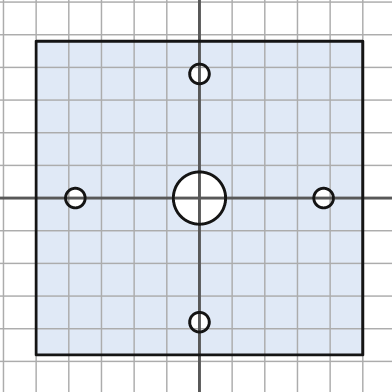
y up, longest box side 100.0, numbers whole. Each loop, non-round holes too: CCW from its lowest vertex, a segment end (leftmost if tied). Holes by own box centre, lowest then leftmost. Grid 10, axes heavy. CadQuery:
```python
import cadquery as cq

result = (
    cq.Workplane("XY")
    .moveTo(-50.0, -48.0)
    .lineTo(50.0, -48.0)
    .lineTo(50.0, 48.0)
    .lineTo(-50.0, 48.0)
    .close()
    .moveTo(0.0, -38.0)
    .circle(3.0)
    .moveTo(-38.0, 0.0)
    .circle(3.0)
    .moveTo(0.0, 0.0)
    .circle(8.0)
    .moveTo(38.0, 0.0)
    .circle(3.0)
    .moveTo(0.0, 38.0)
    .circle(3.0)
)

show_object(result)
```